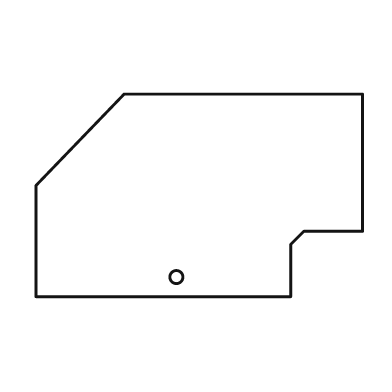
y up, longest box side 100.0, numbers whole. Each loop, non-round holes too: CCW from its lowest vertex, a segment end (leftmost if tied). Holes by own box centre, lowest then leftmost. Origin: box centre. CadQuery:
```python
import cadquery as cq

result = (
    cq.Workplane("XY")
    .moveTo(-50.0, -31.0)
    .lineTo(28.0, -31.0)
    .lineTo(28.0, -15.0)
    .lineTo(32.0, -11.0)
    .lineTo(50.0, -11.0)
    .lineTo(50.0, 31.0)
    .lineTo(-23.0, 31.0)
    .lineTo(-50.0, 3.0)
    .close()
    .moveTo(-7.0, -25.0)
    .circle(2.0)
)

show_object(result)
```